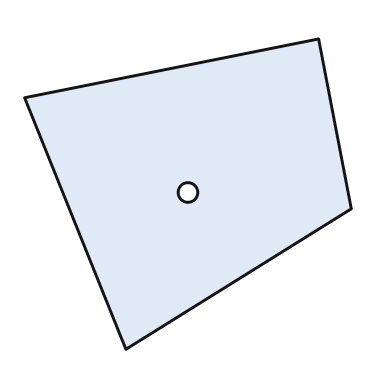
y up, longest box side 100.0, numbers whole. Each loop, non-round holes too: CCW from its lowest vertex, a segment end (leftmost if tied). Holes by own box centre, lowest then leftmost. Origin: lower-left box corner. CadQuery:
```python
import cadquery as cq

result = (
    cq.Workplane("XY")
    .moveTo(31.0, 0.0)
    .lineTo(100.0, 43.0)
    .lineTo(90.0, 95.0)
    .lineTo(0.0, 77.0)
    .close()
    .moveTo(50.0, 48.0)
    .circle(3.0)
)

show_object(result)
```